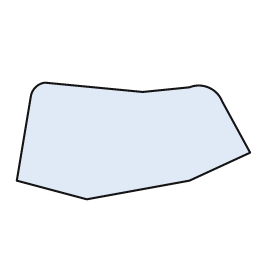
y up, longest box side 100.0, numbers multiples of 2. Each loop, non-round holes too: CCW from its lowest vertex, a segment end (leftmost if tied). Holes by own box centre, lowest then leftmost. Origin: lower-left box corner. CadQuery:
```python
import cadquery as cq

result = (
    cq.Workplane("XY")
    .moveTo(30.0, 0.0)
    .lineTo(74.0, 8.0)
    .lineTo(100.0, 20.0)
    .lineTo(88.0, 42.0)
    .threePointArc((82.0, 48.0), (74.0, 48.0))
    .lineTo(54.0, 46.0)
    .lineTo(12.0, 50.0)
    .threePointArc((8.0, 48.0), (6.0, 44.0))
    .lineTo(0.0, 8.0)
    .close()
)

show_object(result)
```